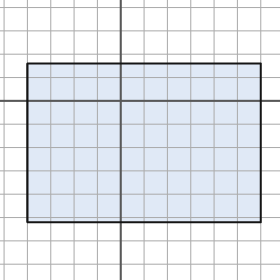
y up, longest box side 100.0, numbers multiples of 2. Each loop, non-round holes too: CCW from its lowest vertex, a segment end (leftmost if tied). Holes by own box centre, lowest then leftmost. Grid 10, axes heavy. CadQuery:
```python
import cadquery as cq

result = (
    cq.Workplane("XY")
    .moveTo(-40.0, -52.0)
    .lineTo(60.0, -52.0)
    .lineTo(60.0, 16.0)
    .lineTo(-40.0, 16.0)
    .close()
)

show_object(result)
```